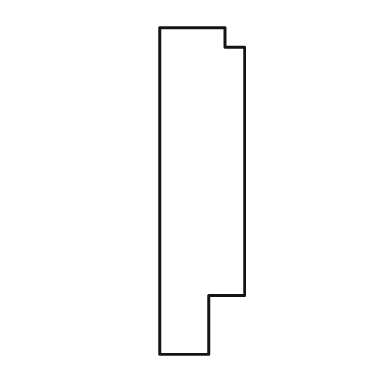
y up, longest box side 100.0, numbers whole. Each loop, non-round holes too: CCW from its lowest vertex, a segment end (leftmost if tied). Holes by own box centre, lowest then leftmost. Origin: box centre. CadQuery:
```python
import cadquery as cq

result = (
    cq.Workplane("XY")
    .moveTo(-13.0, -50.0)
    .lineTo(2.0, -50.0)
    .lineTo(2.0, -32.0)
    .lineTo(13.0, -32.0)
    .lineTo(13.0, 44.0)
    .lineTo(7.0, 44.0)
    .lineTo(7.0, 50.0)
    .lineTo(-13.0, 50.0)
    .close()
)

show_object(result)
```